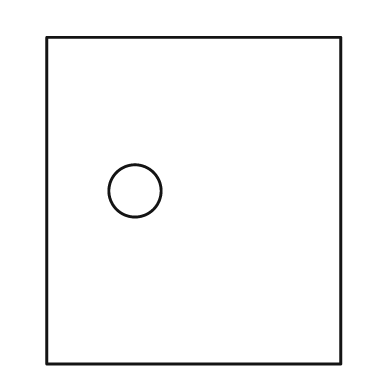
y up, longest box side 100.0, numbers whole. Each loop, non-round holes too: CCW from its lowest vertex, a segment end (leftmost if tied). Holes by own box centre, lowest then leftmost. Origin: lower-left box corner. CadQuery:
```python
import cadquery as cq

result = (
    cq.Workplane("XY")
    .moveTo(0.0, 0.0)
    .lineTo(90.0, 0.0)
    .lineTo(90.0, 100.0)
    .lineTo(0.0, 100.0)
    .close()
    .moveTo(27.0, 53.0)
    .circle(8.0)
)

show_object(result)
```